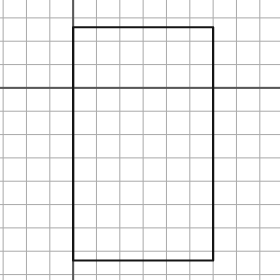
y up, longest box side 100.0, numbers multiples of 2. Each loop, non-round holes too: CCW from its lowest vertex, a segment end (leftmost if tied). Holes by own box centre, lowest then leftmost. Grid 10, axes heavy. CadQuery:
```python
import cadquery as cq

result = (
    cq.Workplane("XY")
    .moveTo(0.0, -74.0)
    .lineTo(60.0, -74.0)
    .lineTo(60.0, 26.0)
    .lineTo(0.0, 26.0)
    .close()
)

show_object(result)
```